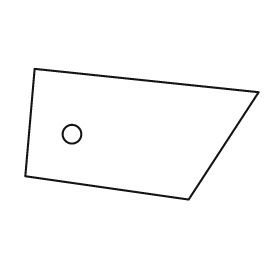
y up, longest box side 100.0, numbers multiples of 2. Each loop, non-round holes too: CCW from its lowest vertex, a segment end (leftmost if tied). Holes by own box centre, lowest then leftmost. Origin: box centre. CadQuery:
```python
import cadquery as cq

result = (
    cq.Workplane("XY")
    .moveTo(20.0, -28.0)
    .lineTo(50.0, 18.0)
    .lineTo(-46.0, 28.0)
    .lineTo(-50.0, -18.0)
    .close()
    .moveTo(-30.0, 0.0)
    .circle(4.0)
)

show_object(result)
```